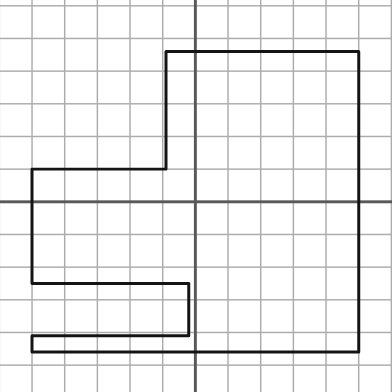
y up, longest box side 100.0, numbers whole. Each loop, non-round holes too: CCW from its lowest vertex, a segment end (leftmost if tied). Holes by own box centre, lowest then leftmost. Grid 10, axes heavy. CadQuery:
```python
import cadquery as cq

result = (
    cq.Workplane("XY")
    .moveTo(-50.0, -46.0)
    .lineTo(50.0, -46.0)
    .lineTo(50.0, 46.0)
    .lineTo(-9.0, 46.0)
    .lineTo(-9.0, 10.0)
    .lineTo(-50.0, 10.0)
    .lineTo(-50.0, -25.0)
    .lineTo(-2.0, -25.0)
    .lineTo(-2.0, -41.0)
    .lineTo(-50.0, -41.0)
    .close()
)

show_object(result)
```